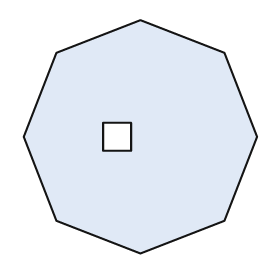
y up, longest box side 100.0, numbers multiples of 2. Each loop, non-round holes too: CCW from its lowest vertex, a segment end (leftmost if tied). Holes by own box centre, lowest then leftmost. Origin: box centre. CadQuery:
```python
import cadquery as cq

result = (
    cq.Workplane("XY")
    .moveTo(0.0, -50.0)
    .lineTo(36.0, -36.0)
    .lineTo(50.0, 0.0)
    .lineTo(36.0, 36.0)
    .lineTo(0.0, 50.0)
    .lineTo(-36.0, 36.0)
    .lineTo(-50.0, 0.0)
    .lineTo(-36.0, -36.0)
    .close()
    .moveTo(-16.0, -6.0)
    .lineTo(-4.0, -6.0)
    .lineTo(-4.0, 6.0)
    .lineTo(-16.0, 6.0)
    .close()
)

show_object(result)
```